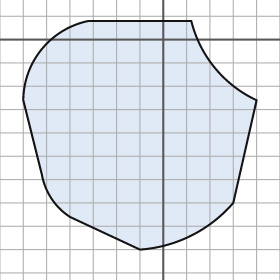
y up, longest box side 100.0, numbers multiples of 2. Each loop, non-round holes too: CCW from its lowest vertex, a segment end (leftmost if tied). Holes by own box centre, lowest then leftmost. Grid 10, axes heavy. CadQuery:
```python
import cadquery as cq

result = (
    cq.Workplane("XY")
    .moveTo(-10.0, -90.0)
    .threePointArc((12.0, -84.0), (30.0, -70.0))
    .lineTo(40.0, -26.0)
    .threePointArc((22.0, -12.0), (12.0, 8.0))
    .lineTo(-32.0, 8.0)
    .threePointArc((-52.0, -4.0), (-60.0, -26.0))
    .lineTo(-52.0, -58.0)
    .threePointArc((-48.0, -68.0), (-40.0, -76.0))
    .close()
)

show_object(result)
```